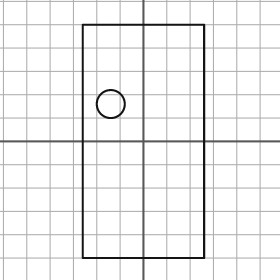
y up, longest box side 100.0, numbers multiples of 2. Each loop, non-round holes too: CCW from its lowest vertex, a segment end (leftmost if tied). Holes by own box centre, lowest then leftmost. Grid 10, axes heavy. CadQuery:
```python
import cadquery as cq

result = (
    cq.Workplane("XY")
    .moveTo(-26.0, -50.0)
    .lineTo(26.0, -50.0)
    .lineTo(26.0, 50.0)
    .lineTo(-26.0, 50.0)
    .close()
    .moveTo(-14.0, 16.0)
    .circle(6.0)
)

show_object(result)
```